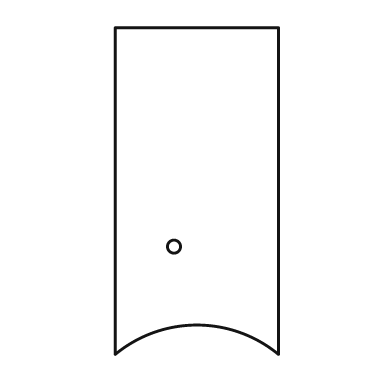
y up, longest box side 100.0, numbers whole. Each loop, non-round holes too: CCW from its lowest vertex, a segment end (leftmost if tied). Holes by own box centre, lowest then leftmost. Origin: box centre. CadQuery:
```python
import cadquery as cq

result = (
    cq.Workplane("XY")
    .moveTo(-25.0, -50.0)
    .threePointArc((0.0, -41.0), (25.0, -50.0))
    .lineTo(25.0, 50.0)
    .lineTo(-25.0, 50.0)
    .close()
    .moveTo(-7.0, -17.0)
    .circle(2.0)
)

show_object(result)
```